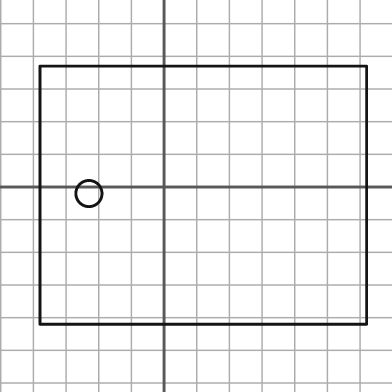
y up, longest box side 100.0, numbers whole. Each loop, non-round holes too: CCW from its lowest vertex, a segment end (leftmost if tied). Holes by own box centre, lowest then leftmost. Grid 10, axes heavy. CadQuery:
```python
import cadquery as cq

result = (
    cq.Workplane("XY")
    .moveTo(-38.0, -42.0)
    .lineTo(62.0, -42.0)
    .lineTo(62.0, 37.0)
    .lineTo(-38.0, 37.0)
    .close()
    .moveTo(-23.0, -2.0)
    .circle(4.0)
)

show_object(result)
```